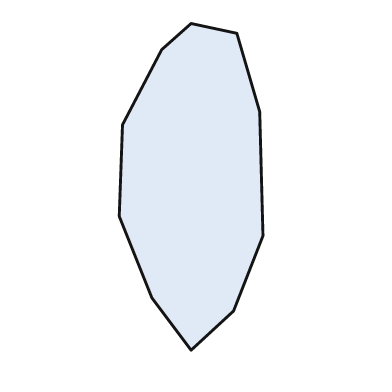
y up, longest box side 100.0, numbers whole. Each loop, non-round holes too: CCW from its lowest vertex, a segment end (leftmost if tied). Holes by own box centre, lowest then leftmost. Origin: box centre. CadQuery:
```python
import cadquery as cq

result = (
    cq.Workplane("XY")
    .moveTo(0.0, -50.0)
    .lineTo(13.0, -38.0)
    .lineTo(22.0, -15.0)
    .lineTo(21.0, 23.0)
    .lineTo(14.0, 47.0)
    .lineTo(0.0, 50.0)
    .lineTo(-9.0, 42.0)
    .lineTo(-21.0, 19.0)
    .lineTo(-22.0, -9.0)
    .lineTo(-12.0, -34.0)
    .close()
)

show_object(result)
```